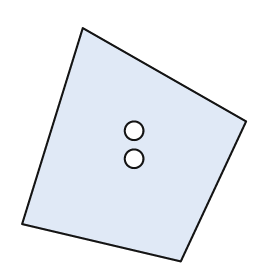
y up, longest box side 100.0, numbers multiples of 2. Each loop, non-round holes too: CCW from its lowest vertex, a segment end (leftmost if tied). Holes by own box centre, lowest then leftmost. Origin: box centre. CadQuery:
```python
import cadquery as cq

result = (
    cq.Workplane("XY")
    .moveTo(20.0, -50.0)
    .lineTo(48.0, 10.0)
    .lineTo(-22.0, 50.0)
    .lineTo(-48.0, -34.0)
    .close()
    .moveTo(0.0, -6.0)
    .circle(4.0)
    .moveTo(0.0, 6.0)
    .circle(4.0)
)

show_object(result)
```